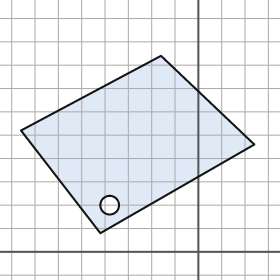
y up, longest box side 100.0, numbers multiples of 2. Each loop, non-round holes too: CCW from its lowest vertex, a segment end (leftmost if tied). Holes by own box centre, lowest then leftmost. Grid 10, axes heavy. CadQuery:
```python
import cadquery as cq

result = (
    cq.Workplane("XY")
    .moveTo(-42.0, 8.0)
    .lineTo(24.0, 46.0)
    .lineTo(-16.0, 84.0)
    .lineTo(-76.0, 52.0)
    .close()
    .moveTo(-38.0, 20.0)
    .circle(4.0)
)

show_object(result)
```